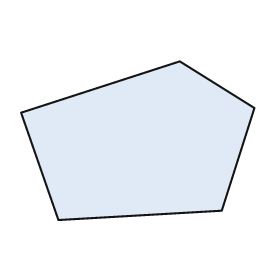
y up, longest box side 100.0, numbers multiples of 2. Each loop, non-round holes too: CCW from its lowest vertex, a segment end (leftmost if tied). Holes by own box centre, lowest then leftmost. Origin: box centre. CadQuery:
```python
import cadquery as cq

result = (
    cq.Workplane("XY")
    .moveTo(-34.0, -34.0)
    .lineTo(36.0, -30.0)
    .lineTo(50.0, 14.0)
    .lineTo(18.0, 34.0)
    .lineTo(-50.0, 12.0)
    .close()
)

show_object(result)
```